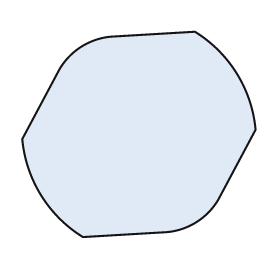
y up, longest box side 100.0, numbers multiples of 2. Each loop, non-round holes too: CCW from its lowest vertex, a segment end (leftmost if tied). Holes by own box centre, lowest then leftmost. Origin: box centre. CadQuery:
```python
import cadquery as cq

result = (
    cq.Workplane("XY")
    .moveTo(-24.0, -44.0)
    .lineTo(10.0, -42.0)
    .threePointArc((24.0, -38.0), (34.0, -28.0))
    .lineTo(50.0, 2.0)
    .threePointArc((42.0, 26.0), (24.0, 44.0))
    .lineTo(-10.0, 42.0)
    .threePointArc((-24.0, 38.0), (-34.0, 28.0))
    .lineTo(-50.0, -2.0)
    .threePointArc((-42.0, -26.0), (-24.0, -44.0))
    .close()
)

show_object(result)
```